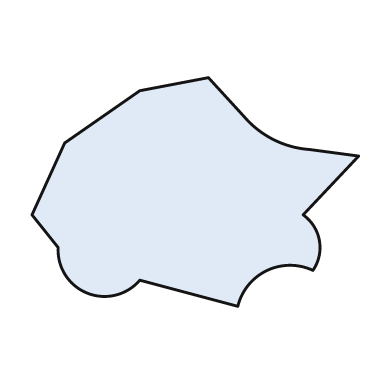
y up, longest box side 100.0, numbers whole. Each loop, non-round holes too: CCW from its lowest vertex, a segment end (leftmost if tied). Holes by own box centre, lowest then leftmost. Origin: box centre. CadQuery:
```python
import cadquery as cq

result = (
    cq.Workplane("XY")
    .moveTo(13.0, -35.0)
    .threePointArc((22.0, -24.0), (36.0, -24.0))
    .threePointArc((38.0, -15.0), (33.0, -7.0))
    .lineTo(50.0, 11.0)
    .lineTo(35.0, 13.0)
    .threePointArc((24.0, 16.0), (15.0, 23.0))
    .lineTo(4.0, 35.0)
    .lineTo(-17.0, 31.0)
    .lineTo(-40.0, 15.0)
    .lineTo(-50.0, -7.0)
    .lineTo(-42.0, -17.0)
    .threePointArc((-33.0, -31.0), (-17.0, -27.0))
    .close()
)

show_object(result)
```